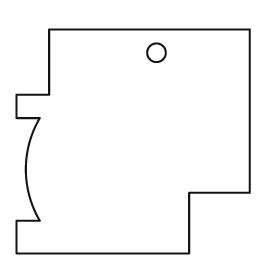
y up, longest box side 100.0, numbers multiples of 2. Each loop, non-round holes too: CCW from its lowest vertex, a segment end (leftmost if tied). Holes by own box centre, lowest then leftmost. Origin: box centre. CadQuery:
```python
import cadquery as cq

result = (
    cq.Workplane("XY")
    .moveTo(-50.0, -48.0)
    .lineTo(24.0, -48.0)
    .lineTo(24.0, -22.0)
    .lineTo(50.0, -22.0)
    .lineTo(50.0, 48.0)
    .lineTo(-36.0, 48.0)
    .lineTo(-36.0, 20.0)
    .lineTo(-50.0, 20.0)
    .lineTo(-50.0, 10.0)
    .lineTo(-40.0, 10.0)
    .threePointArc((-46.0, -12.0), (-40.0, -34.0))
    .lineTo(-50.0, -34.0)
    .close()
    .moveTo(10.0, 38.0)
    .circle(4.0)
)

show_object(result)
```